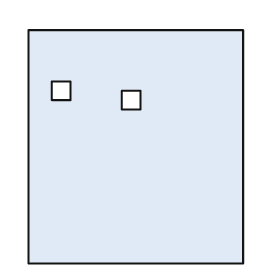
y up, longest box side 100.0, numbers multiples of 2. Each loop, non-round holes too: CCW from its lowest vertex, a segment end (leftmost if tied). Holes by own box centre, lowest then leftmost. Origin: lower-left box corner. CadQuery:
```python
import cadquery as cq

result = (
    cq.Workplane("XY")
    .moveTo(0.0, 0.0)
    .lineTo(92.0, 0.0)
    .lineTo(92.0, 100.0)
    .lineTo(0.0, 100.0)
    .close()
    .moveTo(40.0, 66.0)
    .lineTo(48.0, 66.0)
    .lineTo(48.0, 74.0)
    .lineTo(40.0, 74.0)
    .close()
    .moveTo(10.0, 70.0)
    .lineTo(18.0, 70.0)
    .lineTo(18.0, 78.0)
    .lineTo(10.0, 78.0)
    .close()
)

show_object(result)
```